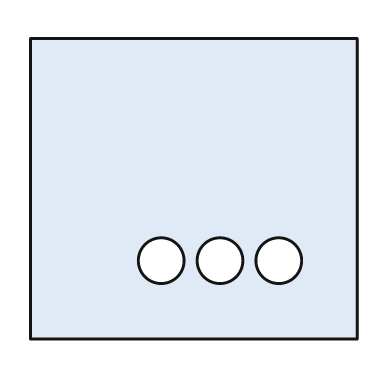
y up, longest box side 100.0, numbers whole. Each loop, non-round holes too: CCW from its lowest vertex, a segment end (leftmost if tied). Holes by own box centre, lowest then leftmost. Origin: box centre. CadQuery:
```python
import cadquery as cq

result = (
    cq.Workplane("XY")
    .moveTo(-50.0, -46.0)
    .lineTo(50.0, -46.0)
    .lineTo(50.0, 46.0)
    .lineTo(-50.0, 46.0)
    .close()
    .moveTo(-10.0, -22.0)
    .circle(7.0)
    .moveTo(8.0, -22.0)
    .circle(7.0)
    .moveTo(26.0, -22.0)
    .circle(7.0)
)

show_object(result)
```